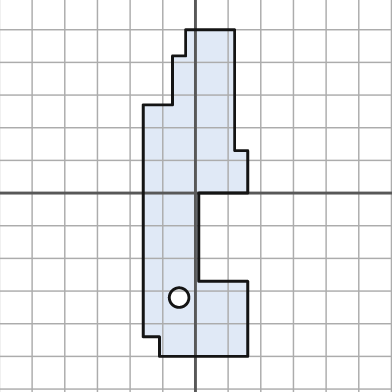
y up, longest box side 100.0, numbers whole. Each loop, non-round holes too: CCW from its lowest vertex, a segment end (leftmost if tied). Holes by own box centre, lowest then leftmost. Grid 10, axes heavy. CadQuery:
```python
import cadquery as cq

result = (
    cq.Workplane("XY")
    .moveTo(-11.0, -50.0)
    .lineTo(16.0, -50.0)
    .lineTo(16.0, -27.0)
    .lineTo(1.0, -27.0)
    .lineTo(1.0, 0.0)
    .lineTo(16.0, 0.0)
    .lineTo(16.0, 13.0)
    .lineTo(12.0, 13.0)
    .lineTo(12.0, 50.0)
    .lineTo(-3.0, 50.0)
    .lineTo(-3.0, 42.0)
    .lineTo(-7.0, 42.0)
    .lineTo(-7.0, 27.0)
    .lineTo(-16.0, 27.0)
    .lineTo(-16.0, -44.0)
    .lineTo(-11.0, -44.0)
    .close()
    .moveTo(-5.0, -32.0)
    .circle(3.0)
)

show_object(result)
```